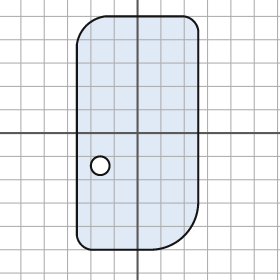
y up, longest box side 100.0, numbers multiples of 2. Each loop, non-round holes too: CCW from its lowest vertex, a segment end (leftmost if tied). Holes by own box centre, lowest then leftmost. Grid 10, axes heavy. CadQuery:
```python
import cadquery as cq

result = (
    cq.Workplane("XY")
    .moveTo(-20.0, -50.0)
    .lineTo(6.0, -50.0)
    .threePointArc((20.0, -44.0), (26.0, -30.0))
    .lineTo(26.0, 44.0)
    .threePointArc((24.0, 48.0), (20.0, 50.0))
    .lineTo(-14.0, 50.0)
    .threePointArc((-22.0, 46.0), (-26.0, 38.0))
    .lineTo(-26.0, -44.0)
    .threePointArc((-24.0, -48.0), (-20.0, -50.0))
    .close()
    .moveTo(-16.0, -14.0)
    .circle(4.0)
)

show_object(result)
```